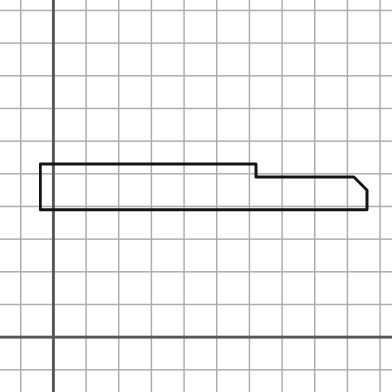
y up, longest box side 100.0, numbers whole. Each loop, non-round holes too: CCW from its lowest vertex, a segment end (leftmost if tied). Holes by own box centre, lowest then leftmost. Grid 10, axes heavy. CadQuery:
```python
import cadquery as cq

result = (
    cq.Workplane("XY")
    .moveTo(-4.0, 39.0)
    .lineTo(96.0, 39.0)
    .lineTo(96.0, 45.0)
    .lineTo(92.0, 49.0)
    .lineTo(62.0, 49.0)
    .lineTo(62.0, 53.0)
    .lineTo(-4.0, 53.0)
    .close()
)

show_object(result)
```